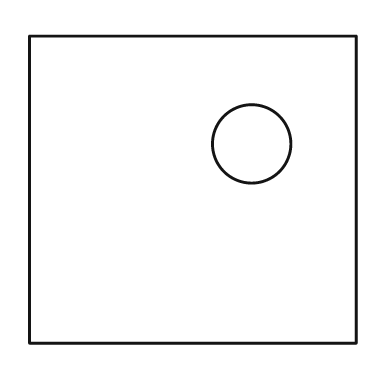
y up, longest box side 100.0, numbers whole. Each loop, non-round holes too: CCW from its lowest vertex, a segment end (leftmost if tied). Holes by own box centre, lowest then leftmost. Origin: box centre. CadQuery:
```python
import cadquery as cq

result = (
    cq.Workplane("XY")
    .moveTo(-50.0, -47.0)
    .lineTo(50.0, -47.0)
    .lineTo(50.0, 47.0)
    .lineTo(-50.0, 47.0)
    .close()
    .moveTo(18.0, 14.0)
    .circle(12.0)
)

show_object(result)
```